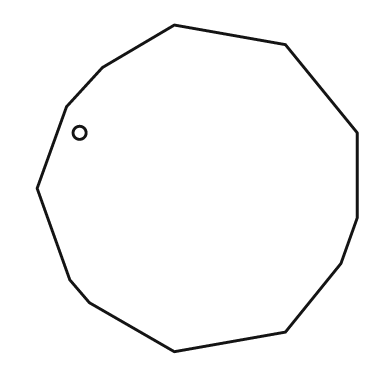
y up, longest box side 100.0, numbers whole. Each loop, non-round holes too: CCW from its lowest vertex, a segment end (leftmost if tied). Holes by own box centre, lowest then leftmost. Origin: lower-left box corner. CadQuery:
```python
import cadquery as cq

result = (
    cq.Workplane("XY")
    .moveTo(42.0, 0.0)
    .lineTo(76.0, 6.0)
    .lineTo(93.0, 27.0)
    .lineTo(98.0, 41.0)
    .lineTo(98.0, 67.0)
    .lineTo(76.0, 94.0)
    .lineTo(42.0, 100.0)
    .lineTo(20.0, 87.0)
    .lineTo(9.0, 75.0)
    .lineTo(0.0, 50.0)
    .lineTo(10.0, 22.0)
    .lineTo(16.0, 15.0)
    .close()
    .moveTo(13.0, 67.0)
    .circle(2.0)
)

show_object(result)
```